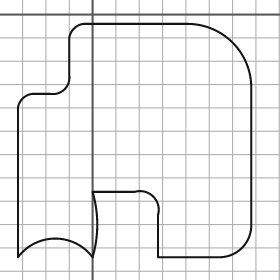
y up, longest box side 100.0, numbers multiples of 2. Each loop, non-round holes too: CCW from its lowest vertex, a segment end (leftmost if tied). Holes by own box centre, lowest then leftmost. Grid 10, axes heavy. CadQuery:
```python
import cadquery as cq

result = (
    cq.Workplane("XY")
    .moveTo(-32.0, -104.0)
    .threePointArc((-16.0, -96.0), (0.0, -104.0))
    .threePointArc((2.0, -90.0), (0.0, -76.0))
    .lineTo(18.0, -76.0)
    .threePointArc((26.0, -78.0), (28.0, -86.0))
    .lineTo(28.0, -104.0)
    .lineTo(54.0, -104.0)
    .threePointArc((64.0, -100.0), (68.0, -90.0))
    .lineTo(68.0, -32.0)
    .threePointArc((60.0, -12.0), (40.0, -4.0))
    .lineTo(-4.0, -4.0)
    .threePointArc((-8.0, -6.0), (-10.0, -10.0))
    .lineTo(-10.0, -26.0)
    .threePointArc((-12.0, -32.0), (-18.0, -34.0))
    .lineTo(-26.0, -34.0)
    .threePointArc((-30.0, -36.0), (-32.0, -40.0))
    .close()
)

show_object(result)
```